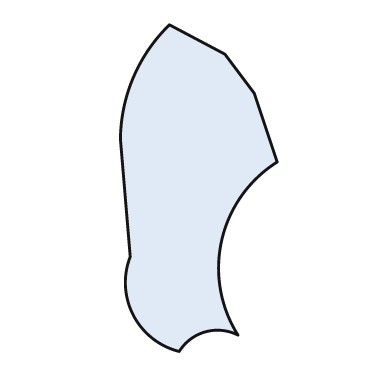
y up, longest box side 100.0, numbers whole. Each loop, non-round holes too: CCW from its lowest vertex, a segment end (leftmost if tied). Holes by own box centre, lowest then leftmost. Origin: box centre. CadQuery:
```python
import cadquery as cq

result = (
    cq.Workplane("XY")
    .moveTo(-6.0, -50.0)
    .threePointArc((2.0, -44.0), (12.0, -45.0))
    .threePointArc((7.0, -16.0), (24.0, 8.0))
    .lineTo(17.0, 29.0)
    .lineTo(8.0, 41.0)
    .lineTo(-9.0, 50.0)
    .threePointArc((-20.0, 34.0), (-24.0, 15.0))
    .lineTo(-21.0, -21.0)
    .threePointArc((-20.0, -39.0), (-6.0, -50.0))
    .close()
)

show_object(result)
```